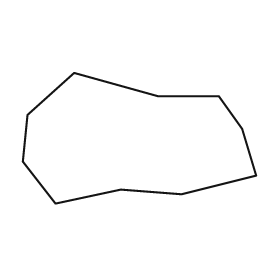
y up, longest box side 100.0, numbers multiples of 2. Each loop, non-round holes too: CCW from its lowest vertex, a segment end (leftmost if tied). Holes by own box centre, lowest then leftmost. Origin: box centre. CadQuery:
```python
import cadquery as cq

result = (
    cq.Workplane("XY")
    .moveTo(-36.0, -28.0)
    .lineTo(-8.0, -22.0)
    .lineTo(18.0, -24.0)
    .lineTo(50.0, -16.0)
    .lineTo(44.0, 4.0)
    .lineTo(34.0, 18.0)
    .lineTo(8.0, 18.0)
    .lineTo(-28.0, 28.0)
    .lineTo(-48.0, 10.0)
    .lineTo(-50.0, -10.0)
    .close()
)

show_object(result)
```